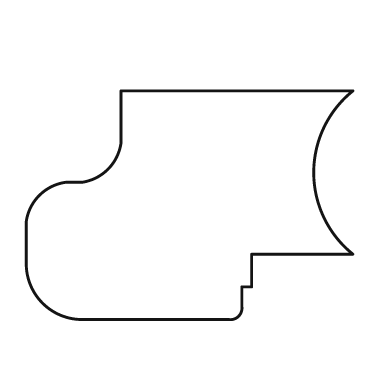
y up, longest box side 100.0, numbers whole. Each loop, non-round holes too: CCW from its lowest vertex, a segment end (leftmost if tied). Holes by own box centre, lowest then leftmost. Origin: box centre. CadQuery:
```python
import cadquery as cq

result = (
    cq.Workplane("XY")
    .moveTo(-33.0, -35.0)
    .lineTo(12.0, -35.0)
    .threePointArc((15.0, -34.0), (16.0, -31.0))
    .lineTo(16.0, -25.0)
    .lineTo(19.0, -25.0)
    .lineTo(19.0, -15.0)
    .lineTo(50.0, -15.0)
    .threePointArc((38.0, 10.0), (50.0, 35.0))
    .lineTo(-21.0, 35.0)
    .lineTo(-21.0, 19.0)
    .threePointArc((-25.0, 11.0), (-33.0, 7.0))
    .lineTo(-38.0, 7.0)
    .threePointArc((-46.0, 3.0), (-50.0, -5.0))
    .lineTo(-50.0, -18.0)
    .threePointArc((-45.0, -30.0), (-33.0, -35.0))
    .close()
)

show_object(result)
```